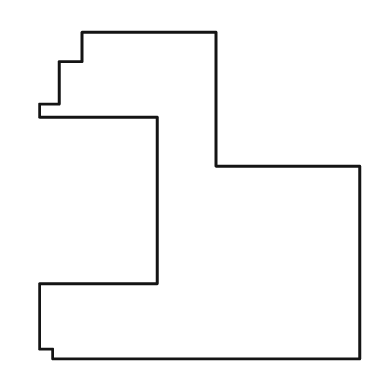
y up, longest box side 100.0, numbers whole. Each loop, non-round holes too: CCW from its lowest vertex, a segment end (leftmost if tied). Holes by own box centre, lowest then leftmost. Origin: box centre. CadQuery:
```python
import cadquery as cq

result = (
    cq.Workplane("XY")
    .moveTo(-45.0, -50.0)
    .lineTo(49.0, -50.0)
    .lineTo(49.0, 9.0)
    .lineTo(5.0, 9.0)
    .lineTo(5.0, 50.0)
    .lineTo(-36.0, 50.0)
    .lineTo(-36.0, 41.0)
    .lineTo(-43.0, 41.0)
    .lineTo(-43.0, 28.0)
    .lineTo(-49.0, 28.0)
    .lineTo(-49.0, 24.0)
    .lineTo(-13.0, 24.0)
    .lineTo(-13.0, -27.0)
    .lineTo(-49.0, -27.0)
    .lineTo(-49.0, -47.0)
    .lineTo(-45.0, -47.0)
    .close()
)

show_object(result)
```